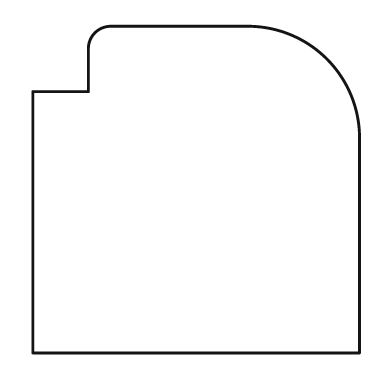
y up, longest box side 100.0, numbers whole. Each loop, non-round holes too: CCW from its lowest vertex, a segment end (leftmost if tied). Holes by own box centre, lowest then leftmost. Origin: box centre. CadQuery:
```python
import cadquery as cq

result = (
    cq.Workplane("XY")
    .moveTo(-50.0, -50.0)
    .lineTo(50.0, -50.0)
    .lineTo(50.0, 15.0)
    .threePointArc((40.0, 40.0), (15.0, 50.0))
    .lineTo(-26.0, 50.0)
    .threePointArc((-31.0, 48.0), (-33.0, 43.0))
    .lineTo(-33.0, 30.0)
    .lineTo(-50.0, 30.0)
    .close()
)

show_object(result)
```